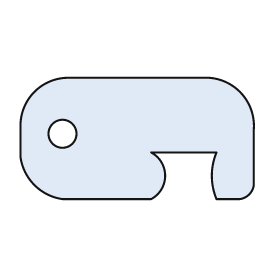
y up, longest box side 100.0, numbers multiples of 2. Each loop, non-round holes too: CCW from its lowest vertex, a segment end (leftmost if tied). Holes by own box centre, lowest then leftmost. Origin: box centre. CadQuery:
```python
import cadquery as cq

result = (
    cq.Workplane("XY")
    .moveTo(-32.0, -26.0)
    .lineTo(6.0, -26.0)
    .threePointArc((12.0, -16.0), (6.0, -6.0))
    .lineTo(34.0, -6.0)
    .threePointArc((32.0, -16.0), (34.0, -26.0))
    .lineTo(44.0, -26.0)
    .threePointArc((48.0, -24.0), (50.0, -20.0))
    .lineTo(50.0, 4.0)
    .threePointArc((44.0, 20.0), (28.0, 26.0))
    .lineTo(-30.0, 26.0)
    .threePointArc((-44.0, 20.0), (-50.0, 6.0))
    .lineTo(-50.0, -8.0)
    .threePointArc((-44.0, -20.0), (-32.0, -26.0))
    .close()
    .moveTo(-32.0, 2.0)
    .circle(6.0)
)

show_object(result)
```